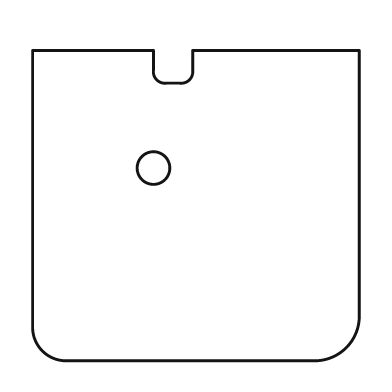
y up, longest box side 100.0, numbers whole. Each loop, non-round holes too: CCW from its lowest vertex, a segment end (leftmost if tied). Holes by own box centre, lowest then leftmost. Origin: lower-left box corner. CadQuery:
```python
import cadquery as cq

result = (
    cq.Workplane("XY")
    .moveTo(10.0, 0.0)
    .lineTo(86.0, 0.0)
    .threePointArc((96.0, 4.0), (100.0, 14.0))
    .lineTo(100.0, 95.0)
    .lineTo(49.0, 95.0)
    .lineTo(49.0, 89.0)
    .threePointArc((48.0, 86.0), (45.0, 85.0))
    .lineTo(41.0, 85.0)
    .threePointArc((38.0, 86.0), (37.0, 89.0))
    .lineTo(37.0, 95.0)
    .lineTo(0.0, 95.0)
    .lineTo(0.0, 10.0)
    .threePointArc((3.0, 3.0), (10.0, 0.0))
    .close()
    .moveTo(37.0, 59.0)
    .circle(5.0)
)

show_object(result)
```